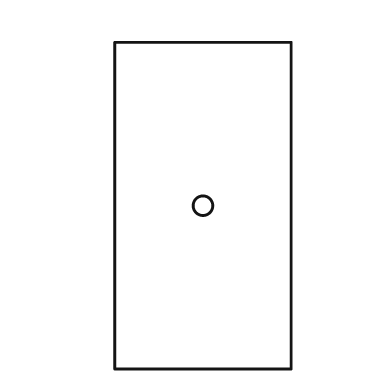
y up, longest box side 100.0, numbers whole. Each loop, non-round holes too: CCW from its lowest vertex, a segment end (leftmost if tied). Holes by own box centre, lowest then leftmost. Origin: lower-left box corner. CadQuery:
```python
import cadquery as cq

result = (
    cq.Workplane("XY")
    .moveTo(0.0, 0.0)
    .lineTo(54.0, 0.0)
    .lineTo(54.0, 100.0)
    .lineTo(0.0, 100.0)
    .close()
    .moveTo(27.0, 50.0)
    .circle(3.0)
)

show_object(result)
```